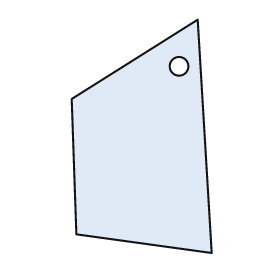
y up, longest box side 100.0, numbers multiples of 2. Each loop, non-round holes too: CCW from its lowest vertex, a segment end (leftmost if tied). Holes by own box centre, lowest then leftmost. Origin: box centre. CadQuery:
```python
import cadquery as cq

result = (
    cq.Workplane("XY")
    .moveTo(30.0, -50.0)
    .lineTo(24.0, 50.0)
    .lineTo(-30.0, 16.0)
    .lineTo(-28.0, -42.0)
    .close()
    .moveTo(16.0, 30.0)
    .circle(4.0)
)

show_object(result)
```